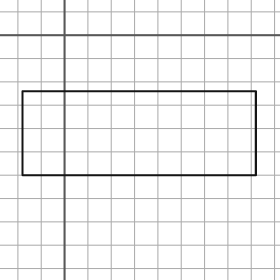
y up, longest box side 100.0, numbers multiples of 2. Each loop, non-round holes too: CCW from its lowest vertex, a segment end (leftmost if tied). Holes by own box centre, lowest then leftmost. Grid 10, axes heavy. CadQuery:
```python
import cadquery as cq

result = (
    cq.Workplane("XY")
    .moveTo(-18.0, -60.0)
    .lineTo(82.0, -60.0)
    .lineTo(82.0, -24.0)
    .lineTo(-18.0, -24.0)
    .close()
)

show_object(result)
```